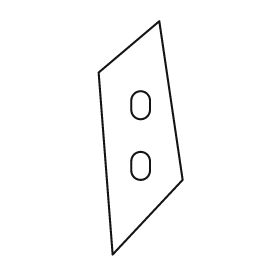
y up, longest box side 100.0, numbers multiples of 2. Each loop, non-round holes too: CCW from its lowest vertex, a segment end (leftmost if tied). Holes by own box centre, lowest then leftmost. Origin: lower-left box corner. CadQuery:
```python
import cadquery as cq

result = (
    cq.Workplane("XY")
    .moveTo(6.0, 0.0)
    .lineTo(36.0, 32.0)
    .lineTo(26.0, 100.0)
    .lineTo(0.0, 78.0)
    .close()
    .moveTo(14.0, 36.0)
    .threePointArc((18.0, 32.0), (22.0, 36.0))
    .lineTo(22.0, 40.0)
    .threePointArc((18.0, 44.0), (14.0, 40.0))
    .close()
    .moveTo(14.0, 62.0)
    .threePointArc((18.0, 58.0), (22.0, 62.0))
    .lineTo(22.0, 66.0)
    .threePointArc((18.0, 70.0), (14.0, 66.0))
    .close()
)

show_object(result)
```